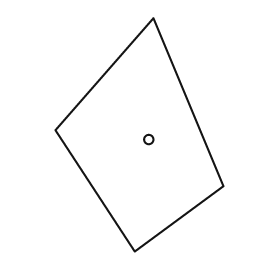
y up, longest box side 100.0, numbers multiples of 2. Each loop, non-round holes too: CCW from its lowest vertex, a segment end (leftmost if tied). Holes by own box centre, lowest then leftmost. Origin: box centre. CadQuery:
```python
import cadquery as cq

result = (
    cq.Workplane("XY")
    .moveTo(-2.0, -50.0)
    .lineTo(36.0, -22.0)
    .lineTo(6.0, 50.0)
    .lineTo(-36.0, 2.0)
    .close()
    .moveTo(4.0, -2.0)
    .circle(2.0)
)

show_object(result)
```